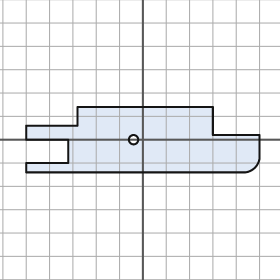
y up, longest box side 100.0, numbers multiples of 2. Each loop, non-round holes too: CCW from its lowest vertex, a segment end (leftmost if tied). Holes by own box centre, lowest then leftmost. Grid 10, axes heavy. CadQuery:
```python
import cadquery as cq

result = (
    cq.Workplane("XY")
    .moveTo(-50.0, -14.0)
    .lineTo(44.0, -14.0)
    .threePointArc((48.0, -12.0), (50.0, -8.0))
    .lineTo(50.0, 2.0)
    .lineTo(30.0, 2.0)
    .lineTo(30.0, 14.0)
    .lineTo(-28.0, 14.0)
    .lineTo(-28.0, 6.0)
    .lineTo(-50.0, 6.0)
    .lineTo(-50.0, 0.0)
    .lineTo(-32.0, 0.0)
    .lineTo(-32.0, -10.0)
    .lineTo(-50.0, -10.0)
    .close()
    .moveTo(-4.0, 0.0)
    .circle(2.0)
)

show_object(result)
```